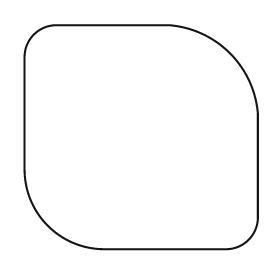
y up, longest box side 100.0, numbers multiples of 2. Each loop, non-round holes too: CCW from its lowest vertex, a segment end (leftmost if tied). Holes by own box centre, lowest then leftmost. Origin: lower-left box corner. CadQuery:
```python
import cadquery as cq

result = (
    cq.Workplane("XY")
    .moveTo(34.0, 0.0)
    .lineTo(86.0, 0.0)
    .threePointArc((96.0, 4.0), (100.0, 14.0))
    .lineTo(100.0, 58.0)
    .threePointArc((88.0, 84.0), (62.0, 96.0))
    .lineTo(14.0, 96.0)
    .threePointArc((4.0, 92.0), (0.0, 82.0))
    .lineTo(0.0, 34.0)
    .threePointArc((10.0, 10.0), (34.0, 0.0))
    .close()
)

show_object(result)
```